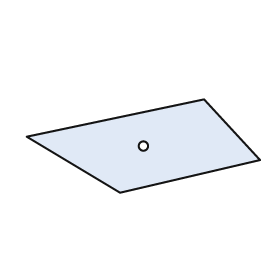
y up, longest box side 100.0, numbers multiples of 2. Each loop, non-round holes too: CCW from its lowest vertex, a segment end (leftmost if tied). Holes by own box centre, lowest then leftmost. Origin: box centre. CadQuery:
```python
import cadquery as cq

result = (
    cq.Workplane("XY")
    .moveTo(-10.0, -20.0)
    .lineTo(50.0, -6.0)
    .lineTo(26.0, 20.0)
    .lineTo(-50.0, 4.0)
    .close()
    .moveTo(0.0, 0.0)
    .circle(2.0)
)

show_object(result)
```